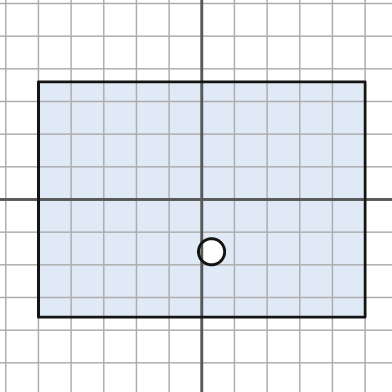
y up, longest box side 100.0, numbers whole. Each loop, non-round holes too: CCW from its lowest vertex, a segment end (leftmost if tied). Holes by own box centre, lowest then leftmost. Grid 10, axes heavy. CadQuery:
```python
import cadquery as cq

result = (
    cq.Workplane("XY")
    .moveTo(-50.0, -36.0)
    .lineTo(50.0, -36.0)
    .lineTo(50.0, 36.0)
    .lineTo(-50.0, 36.0)
    .close()
    .moveTo(3.0, -16.0)
    .circle(4.0)
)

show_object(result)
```